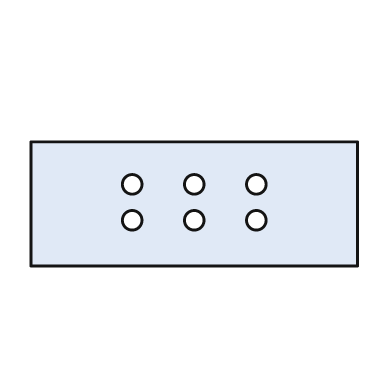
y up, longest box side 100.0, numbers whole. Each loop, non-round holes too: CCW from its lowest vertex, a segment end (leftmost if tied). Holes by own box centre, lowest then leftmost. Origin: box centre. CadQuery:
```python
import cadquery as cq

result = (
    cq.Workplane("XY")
    .moveTo(-50.0, -19.0)
    .lineTo(50.0, -19.0)
    .lineTo(50.0, 19.0)
    .lineTo(-50.0, 19.0)
    .close()
    .moveTo(-19.0, -5.0)
    .circle(3.0)
    .moveTo(0.0, -5.0)
    .circle(3.0)
    .moveTo(19.0, -5.0)
    .circle(3.0)
    .moveTo(-19.0, 6.0)
    .circle(3.0)
    .moveTo(0.0, 6.0)
    .circle(3.0)
    .moveTo(19.0, 6.0)
    .circle(3.0)
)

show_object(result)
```